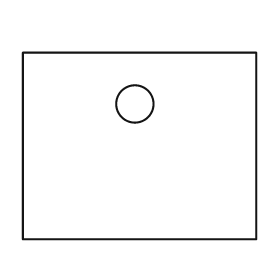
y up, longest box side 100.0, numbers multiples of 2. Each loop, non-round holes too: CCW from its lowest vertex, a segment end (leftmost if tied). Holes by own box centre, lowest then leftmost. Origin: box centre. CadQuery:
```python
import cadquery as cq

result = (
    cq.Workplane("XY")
    .moveTo(-50.0, -40.0)
    .lineTo(50.0, -40.0)
    .lineTo(50.0, 40.0)
    .lineTo(-50.0, 40.0)
    .close()
    .moveTo(-2.0, 18.0)
    .circle(8.0)
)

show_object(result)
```